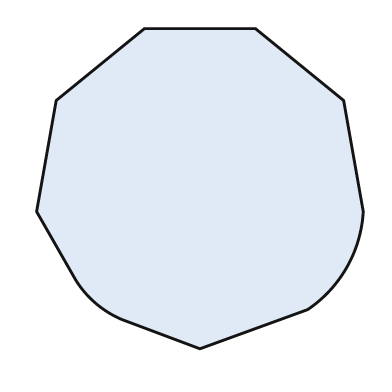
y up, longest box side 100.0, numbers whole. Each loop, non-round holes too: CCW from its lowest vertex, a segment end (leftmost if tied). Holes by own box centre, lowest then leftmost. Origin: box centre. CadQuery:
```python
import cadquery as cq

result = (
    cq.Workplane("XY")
    .moveTo(0.0, -49.0)
    .lineTo(33.0, -37.0)
    .threePointArc((45.0, -24.0), (50.0, -7.0))
    .lineTo(44.0, 27.0)
    .lineTo(17.0, 49.0)
    .lineTo(-17.0, 49.0)
    .lineTo(-44.0, 27.0)
    .lineTo(-50.0, -7.0)
    .lineTo(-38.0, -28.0)
    .threePointArc((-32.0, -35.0), (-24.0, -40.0))
    .close()
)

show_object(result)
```